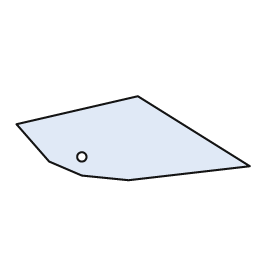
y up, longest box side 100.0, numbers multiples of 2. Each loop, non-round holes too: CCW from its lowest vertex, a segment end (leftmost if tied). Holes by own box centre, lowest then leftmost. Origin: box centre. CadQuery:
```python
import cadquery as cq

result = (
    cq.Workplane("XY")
    .moveTo(-2.0, -18.0)
    .lineTo(50.0, -12.0)
    .lineTo(2.0, 18.0)
    .lineTo(-50.0, 6.0)
    .lineTo(-36.0, -10.0)
    .lineTo(-22.0, -16.0)
    .close()
    .moveTo(-22.0, -8.0)
    .circle(2.0)
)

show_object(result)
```